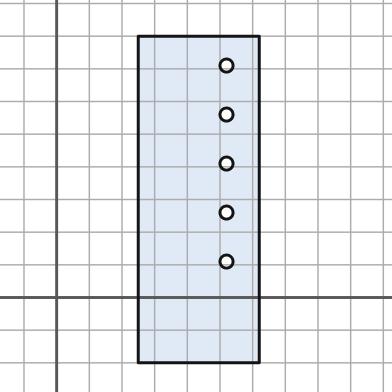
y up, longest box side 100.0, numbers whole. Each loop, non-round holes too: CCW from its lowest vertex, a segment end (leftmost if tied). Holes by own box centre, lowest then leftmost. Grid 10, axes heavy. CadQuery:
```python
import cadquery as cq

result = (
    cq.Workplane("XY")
    .moveTo(25.0, -20.0)
    .lineTo(62.0, -20.0)
    .lineTo(62.0, 80.0)
    .lineTo(25.0, 80.0)
    .close()
    .moveTo(52.0, 11.0)
    .circle(2.0)
    .moveTo(52.0, 26.0)
    .circle(2.0)
    .moveTo(52.0, 41.0)
    .circle(2.0)
    .moveTo(52.0, 56.0)
    .circle(2.0)
    .moveTo(52.0, 71.0)
    .circle(2.0)
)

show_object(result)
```